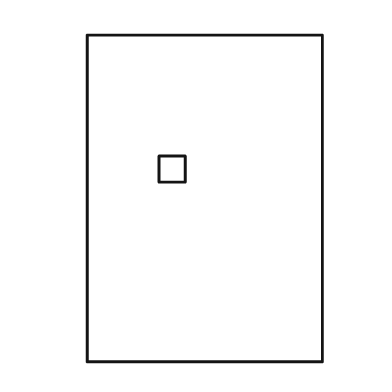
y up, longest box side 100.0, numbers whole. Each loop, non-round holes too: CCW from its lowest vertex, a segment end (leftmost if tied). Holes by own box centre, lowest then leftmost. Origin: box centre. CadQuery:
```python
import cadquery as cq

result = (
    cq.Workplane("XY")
    .moveTo(-36.0, -50.0)
    .lineTo(36.0, -50.0)
    .lineTo(36.0, 50.0)
    .lineTo(-36.0, 50.0)
    .close()
    .moveTo(-14.0, 5.0)
    .lineTo(-6.0, 5.0)
    .lineTo(-6.0, 13.0)
    .lineTo(-14.0, 13.0)
    .close()
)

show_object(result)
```